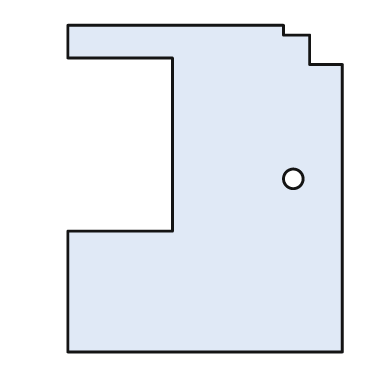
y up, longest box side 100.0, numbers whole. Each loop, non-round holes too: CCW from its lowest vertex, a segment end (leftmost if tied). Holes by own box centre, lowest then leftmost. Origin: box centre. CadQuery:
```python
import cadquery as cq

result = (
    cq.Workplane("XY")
    .moveTo(-42.0, -50.0)
    .lineTo(42.0, -50.0)
    .lineTo(42.0, 38.0)
    .lineTo(32.0, 38.0)
    .lineTo(32.0, 47.0)
    .lineTo(24.0, 47.0)
    .lineTo(24.0, 50.0)
    .lineTo(-42.0, 50.0)
    .lineTo(-42.0, 40.0)
    .lineTo(-10.0, 40.0)
    .lineTo(-10.0, -13.0)
    .lineTo(-42.0, -13.0)
    .close()
    .moveTo(27.0, 3.0)
    .circle(3.0)
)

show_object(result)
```